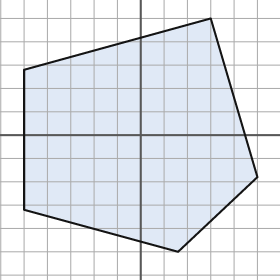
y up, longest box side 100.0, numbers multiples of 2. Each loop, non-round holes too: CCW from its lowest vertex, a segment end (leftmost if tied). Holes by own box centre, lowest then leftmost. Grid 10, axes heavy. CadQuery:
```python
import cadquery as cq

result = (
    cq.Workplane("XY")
    .moveTo(16.0, -50.0)
    .lineTo(50.0, -18.0)
    .lineTo(30.0, 50.0)
    .lineTo(-50.0, 28.0)
    .lineTo(-50.0, -32.0)
    .close()
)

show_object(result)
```